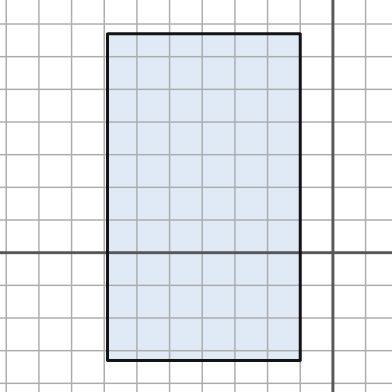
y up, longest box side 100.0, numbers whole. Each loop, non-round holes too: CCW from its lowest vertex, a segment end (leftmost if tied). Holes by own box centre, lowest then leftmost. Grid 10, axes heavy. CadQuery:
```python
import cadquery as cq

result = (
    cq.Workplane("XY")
    .moveTo(-69.0, -33.0)
    .lineTo(-10.0, -33.0)
    .lineTo(-10.0, 67.0)
    .lineTo(-69.0, 67.0)
    .close()
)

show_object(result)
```